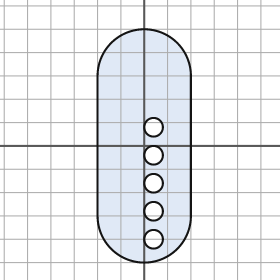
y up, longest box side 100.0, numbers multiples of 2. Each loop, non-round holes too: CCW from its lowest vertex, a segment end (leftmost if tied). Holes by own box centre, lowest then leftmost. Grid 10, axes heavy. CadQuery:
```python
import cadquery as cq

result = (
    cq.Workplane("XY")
    .moveTo(-20.0, -30.0)
    .threePointArc((0.0, -50.0), (20.0, -30.0))
    .lineTo(20.0, 30.0)
    .threePointArc((0.0, 50.0), (-20.0, 30.0))
    .close()
    .moveTo(4.0, -40.0)
    .circle(4.0)
    .moveTo(4.0, -28.0)
    .circle(4.0)
    .moveTo(4.0, -16.0)
    .circle(4.0)
    .moveTo(4.0, -4.0)
    .circle(4.0)
    .moveTo(4.0, 8.0)
    .circle(4.0)
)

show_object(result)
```